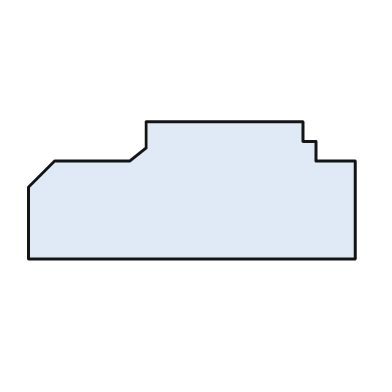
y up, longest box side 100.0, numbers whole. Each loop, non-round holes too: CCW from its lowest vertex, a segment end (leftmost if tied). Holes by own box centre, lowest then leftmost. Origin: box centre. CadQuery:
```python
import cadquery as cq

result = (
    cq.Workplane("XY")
    .moveTo(-50.0, -21.0)
    .lineTo(50.0, -21.0)
    .lineTo(50.0, 9.0)
    .lineTo(38.0, 9.0)
    .lineTo(38.0, 15.0)
    .lineTo(34.0, 15.0)
    .lineTo(34.0, 21.0)
    .lineTo(-14.0, 21.0)
    .lineTo(-14.0, 13.0)
    .lineTo(-19.0, 9.0)
    .lineTo(-42.0, 9.0)
    .lineTo(-50.0, 1.0)
    .close()
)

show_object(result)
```